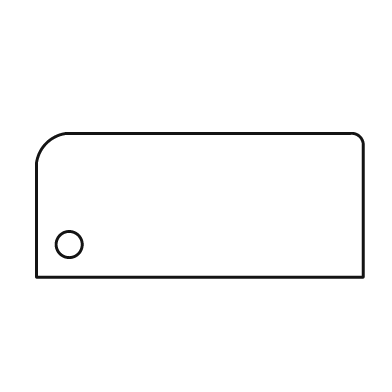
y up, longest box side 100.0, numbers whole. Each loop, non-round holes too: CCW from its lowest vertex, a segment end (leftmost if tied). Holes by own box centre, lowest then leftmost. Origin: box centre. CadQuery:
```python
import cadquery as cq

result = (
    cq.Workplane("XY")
    .moveTo(-50.0, -22.0)
    .lineTo(50.0, -22.0)
    .lineTo(50.0, 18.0)
    .threePointArc((49.0, 21.0), (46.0, 22.0))
    .lineTo(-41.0, 22.0)
    .threePointArc((-47.0, 19.0), (-50.0, 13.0))
    .close()
    .moveTo(-40.0, -12.0)
    .circle(4.0)
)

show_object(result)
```